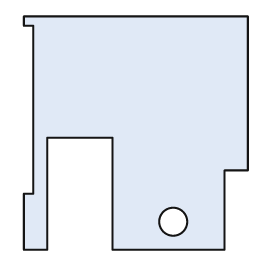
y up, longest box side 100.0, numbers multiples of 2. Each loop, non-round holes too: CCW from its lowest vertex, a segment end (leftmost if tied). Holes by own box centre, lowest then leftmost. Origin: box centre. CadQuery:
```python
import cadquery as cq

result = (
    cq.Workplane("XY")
    .moveTo(-48.0, -50.0)
    .lineTo(-38.0, -50.0)
    .lineTo(-38.0, -2.0)
    .lineTo(-10.0, -2.0)
    .lineTo(-10.0, -50.0)
    .lineTo(38.0, -50.0)
    .lineTo(38.0, -16.0)
    .lineTo(48.0, -16.0)
    .lineTo(48.0, 50.0)
    .lineTo(-48.0, 50.0)
    .lineTo(-48.0, 46.0)
    .lineTo(-44.0, 46.0)
    .lineTo(-44.0, -26.0)
    .lineTo(-48.0, -26.0)
    .close()
    .moveTo(16.0, -38.0)
    .circle(6.0)
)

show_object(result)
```